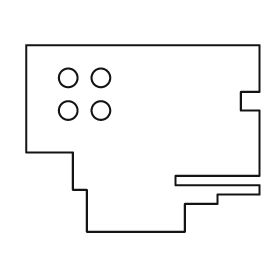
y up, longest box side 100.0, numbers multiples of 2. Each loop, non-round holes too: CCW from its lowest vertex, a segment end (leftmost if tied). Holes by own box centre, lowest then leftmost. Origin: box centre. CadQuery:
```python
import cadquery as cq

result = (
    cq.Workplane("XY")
    .moveTo(-24.0, -40.0)
    .lineTo(18.0, -40.0)
    .lineTo(18.0, -28.0)
    .lineTo(32.0, -28.0)
    .lineTo(32.0, -24.0)
    .lineTo(50.0, -24.0)
    .lineTo(50.0, -20.0)
    .lineTo(14.0, -20.0)
    .lineTo(14.0, -16.0)
    .lineTo(50.0, -16.0)
    .lineTo(50.0, 12.0)
    .lineTo(42.0, 12.0)
    .lineTo(42.0, 20.0)
    .lineTo(50.0, 20.0)
    .lineTo(50.0, 40.0)
    .lineTo(-50.0, 40.0)
    .lineTo(-50.0, -6.0)
    .lineTo(-30.0, -6.0)
    .lineTo(-30.0, -22.0)
    .lineTo(-24.0, -22.0)
    .close()
    .moveTo(-32.0, 12.0)
    .circle(4.0)
    .moveTo(-18.0, 12.0)
    .circle(4.0)
    .moveTo(-32.0, 26.0)
    .circle(4.0)
    .moveTo(-18.0, 26.0)
    .circle(4.0)
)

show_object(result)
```